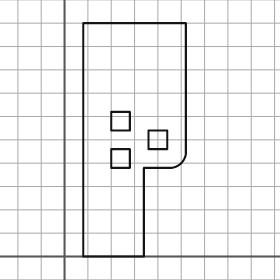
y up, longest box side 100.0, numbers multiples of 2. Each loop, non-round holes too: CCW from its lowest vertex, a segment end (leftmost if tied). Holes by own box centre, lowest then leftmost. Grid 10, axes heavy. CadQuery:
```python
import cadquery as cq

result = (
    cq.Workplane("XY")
    .moveTo(8.0, 0.0)
    .lineTo(34.0, 0.0)
    .lineTo(34.0, 38.0)
    .lineTo(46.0, 38.0)
    .threePointArc((50.0, 40.0), (52.0, 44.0))
    .lineTo(52.0, 100.0)
    .lineTo(8.0, 100.0)
    .close()
    .moveTo(20.0, 38.0)
    .lineTo(28.0, 38.0)
    .lineTo(28.0, 46.0)
    .lineTo(20.0, 46.0)
    .close()
    .moveTo(36.0, 46.0)
    .lineTo(44.0, 46.0)
    .lineTo(44.0, 54.0)
    .lineTo(36.0, 54.0)
    .close()
    .moveTo(20.0, 54.0)
    .lineTo(28.0, 54.0)
    .lineTo(28.0, 62.0)
    .lineTo(20.0, 62.0)
    .close()
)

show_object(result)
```